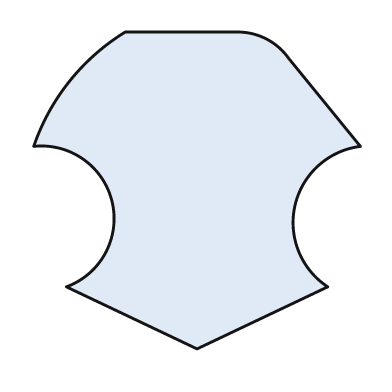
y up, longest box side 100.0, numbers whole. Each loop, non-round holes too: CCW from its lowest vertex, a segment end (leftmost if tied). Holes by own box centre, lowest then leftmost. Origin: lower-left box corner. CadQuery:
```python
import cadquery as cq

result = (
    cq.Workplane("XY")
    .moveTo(50.0, 0.0)
    .lineTo(90.0, 19.0)
    .threePointArc((80.0, 44.0), (100.0, 62.0))
    .lineTo(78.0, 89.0)
    .threePointArc((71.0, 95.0), (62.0, 97.0))
    .lineTo(28.0, 97.0)
    .threePointArc((11.0, 82.0), (0.0, 62.0))
    .threePointArc((24.0, 45.0), (10.0, 19.0))
    .close()
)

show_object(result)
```